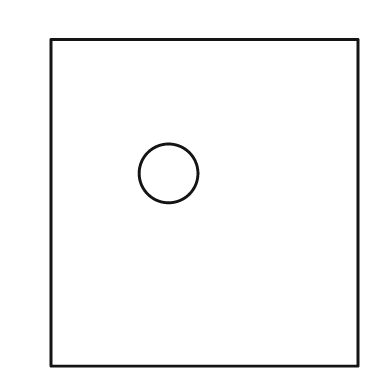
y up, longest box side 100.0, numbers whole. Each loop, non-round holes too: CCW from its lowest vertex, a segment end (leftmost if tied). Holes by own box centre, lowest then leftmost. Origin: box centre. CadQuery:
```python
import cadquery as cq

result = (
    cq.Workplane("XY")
    .moveTo(-47.0, -50.0)
    .lineTo(47.0, -50.0)
    .lineTo(47.0, 50.0)
    .lineTo(-47.0, 50.0)
    .close()
    .moveTo(-11.0, 9.0)
    .circle(9.0)
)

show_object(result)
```